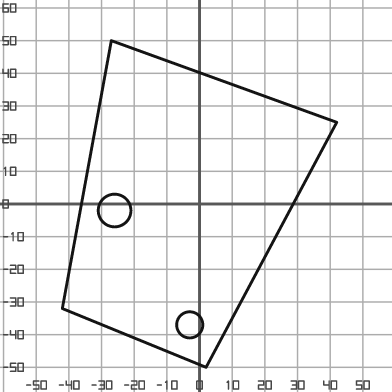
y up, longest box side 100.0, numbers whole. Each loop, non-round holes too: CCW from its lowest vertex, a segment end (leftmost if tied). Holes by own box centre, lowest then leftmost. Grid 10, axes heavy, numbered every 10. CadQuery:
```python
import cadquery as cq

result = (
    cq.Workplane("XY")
    .moveTo(2.0, -50.0)
    .lineTo(42.0, 25.0)
    .lineTo(-27.0, 50.0)
    .lineTo(-42.0, -32.0)
    .close()
    .moveTo(-3.0, -37.0)
    .circle(4.0)
    .moveTo(-26.0, -2.0)
    .circle(5.0)
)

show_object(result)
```